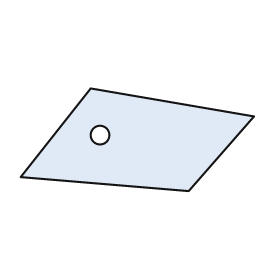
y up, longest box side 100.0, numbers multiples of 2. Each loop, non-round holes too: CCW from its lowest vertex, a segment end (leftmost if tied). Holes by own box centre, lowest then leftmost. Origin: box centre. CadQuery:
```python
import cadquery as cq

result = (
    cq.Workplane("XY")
    .moveTo(22.0, -22.0)
    .lineTo(50.0, 10.0)
    .lineTo(-20.0, 22.0)
    .lineTo(-50.0, -16.0)
    .close()
    .moveTo(-16.0, 2.0)
    .circle(4.0)
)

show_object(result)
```